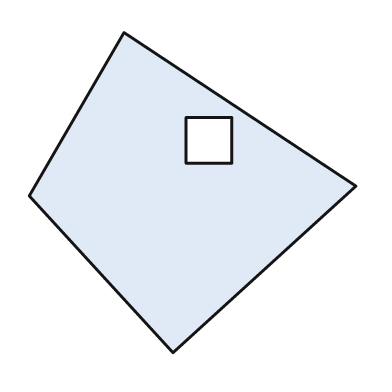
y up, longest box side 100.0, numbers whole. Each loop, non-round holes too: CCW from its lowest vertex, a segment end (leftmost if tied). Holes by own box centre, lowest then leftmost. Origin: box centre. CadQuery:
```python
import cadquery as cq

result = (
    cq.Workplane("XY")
    .moveTo(-6.0, -49.0)
    .lineTo(50.0, 2.0)
    .lineTo(-21.0, 49.0)
    .lineTo(-50.0, -1.0)
    .close()
    .moveTo(-2.0, 9.0)
    .lineTo(12.0, 9.0)
    .lineTo(12.0, 23.0)
    .lineTo(-2.0, 23.0)
    .close()
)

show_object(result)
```